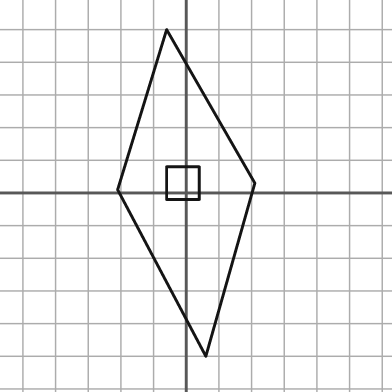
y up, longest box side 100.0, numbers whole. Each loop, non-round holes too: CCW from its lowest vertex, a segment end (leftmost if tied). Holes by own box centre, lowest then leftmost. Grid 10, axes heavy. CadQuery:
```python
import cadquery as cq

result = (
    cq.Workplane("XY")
    .moveTo(6.0, -50.0)
    .lineTo(21.0, 3.0)
    .lineTo(-6.0, 50.0)
    .lineTo(-21.0, 1.0)
    .close()
    .moveTo(-6.0, -2.0)
    .lineTo(4.0, -2.0)
    .lineTo(4.0, 8.0)
    .lineTo(-6.0, 8.0)
    .close()
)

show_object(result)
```